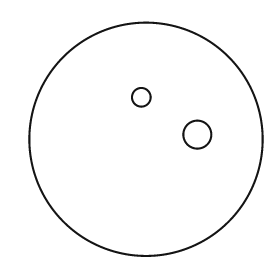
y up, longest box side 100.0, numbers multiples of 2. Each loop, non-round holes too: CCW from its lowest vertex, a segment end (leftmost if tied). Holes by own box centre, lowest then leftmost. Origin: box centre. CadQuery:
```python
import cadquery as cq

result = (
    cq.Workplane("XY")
    .moveTo(0.0, 0.0)
    .circle(50.0)
    .moveTo(22.0, 2.0)
    .circle(6.0)
    .moveTo(-2.0, 18.0)
    .circle(4.0)
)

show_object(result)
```